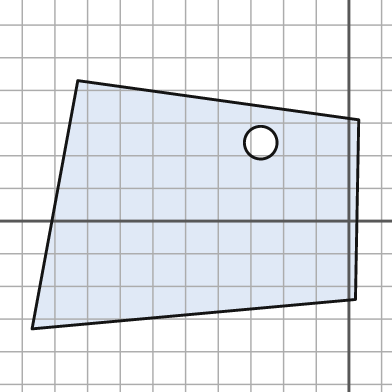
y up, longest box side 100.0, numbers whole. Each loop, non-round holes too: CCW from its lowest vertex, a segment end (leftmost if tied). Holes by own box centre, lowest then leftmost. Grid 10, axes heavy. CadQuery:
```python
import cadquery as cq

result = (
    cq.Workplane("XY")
    .moveTo(-97.0, -33.0)
    .lineTo(2.0, -24.0)
    .lineTo(3.0, 31.0)
    .lineTo(-83.0, 43.0)
    .close()
    .moveTo(-27.0, 24.0)
    .circle(5.0)
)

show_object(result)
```